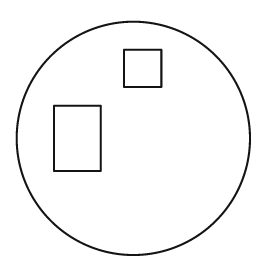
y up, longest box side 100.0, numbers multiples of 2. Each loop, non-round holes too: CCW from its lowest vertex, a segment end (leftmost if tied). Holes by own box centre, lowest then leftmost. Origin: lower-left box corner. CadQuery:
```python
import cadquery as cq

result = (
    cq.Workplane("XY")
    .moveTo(50.0, 50.0)
    .circle(50.0)
    .moveTo(16.0, 36.0)
    .lineTo(36.0, 36.0)
    .lineTo(36.0, 64.0)
    .lineTo(16.0, 64.0)
    .close()
    .moveTo(46.0, 72.0)
    .lineTo(62.0, 72.0)
    .lineTo(62.0, 88.0)
    .lineTo(46.0, 88.0)
    .close()
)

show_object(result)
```